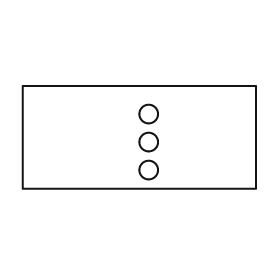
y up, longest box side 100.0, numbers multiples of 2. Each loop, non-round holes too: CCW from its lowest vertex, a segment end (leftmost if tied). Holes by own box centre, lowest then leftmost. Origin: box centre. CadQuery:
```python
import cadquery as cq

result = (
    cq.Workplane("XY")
    .moveTo(-50.0, -22.0)
    .lineTo(50.0, -22.0)
    .lineTo(50.0, 22.0)
    .lineTo(-50.0, 22.0)
    .close()
    .moveTo(4.0, -14.0)
    .circle(4.0)
    .moveTo(4.0, -2.0)
    .circle(4.0)
    .moveTo(4.0, 10.0)
    .circle(4.0)
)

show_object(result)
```